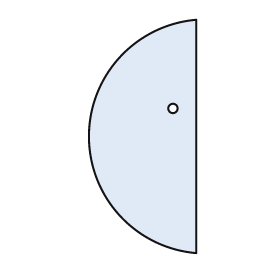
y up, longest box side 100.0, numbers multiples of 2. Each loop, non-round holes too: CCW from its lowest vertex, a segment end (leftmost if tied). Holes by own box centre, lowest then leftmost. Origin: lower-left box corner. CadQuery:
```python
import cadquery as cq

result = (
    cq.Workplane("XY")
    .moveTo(46.0, 0.0)
    .lineTo(46.0, 100.0)
    .threePointArc((0.0, 50.0), (46.0, 0.0))
    .close()
    .moveTo(36.0, 62.0)
    .circle(2.0)
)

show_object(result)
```